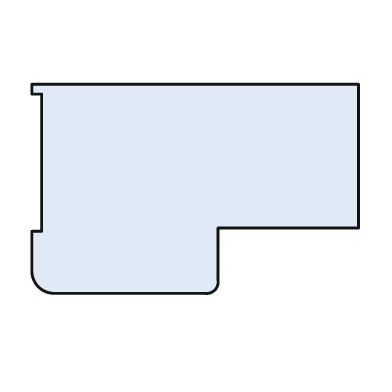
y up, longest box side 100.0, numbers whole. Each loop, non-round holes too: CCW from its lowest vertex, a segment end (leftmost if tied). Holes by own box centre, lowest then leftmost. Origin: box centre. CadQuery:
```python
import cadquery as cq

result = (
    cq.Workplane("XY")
    .moveTo(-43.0, -32.0)
    .lineTo(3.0, -32.0)
    .threePointArc((6.0, -31.0), (7.0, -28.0))
    .lineTo(7.0, -12.0)
    .lineTo(50.0, -12.0)
    .lineTo(50.0, 32.0)
    .lineTo(-50.0, 32.0)
    .lineTo(-50.0, 29.0)
    .lineTo(-47.0, 29.0)
    .lineTo(-47.0, -13.0)
    .lineTo(-50.0, -13.0)
    .lineTo(-50.0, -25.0)
    .threePointArc((-48.0, -30.0), (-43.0, -32.0))
    .close()
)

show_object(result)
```